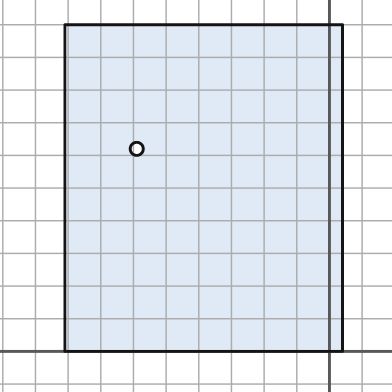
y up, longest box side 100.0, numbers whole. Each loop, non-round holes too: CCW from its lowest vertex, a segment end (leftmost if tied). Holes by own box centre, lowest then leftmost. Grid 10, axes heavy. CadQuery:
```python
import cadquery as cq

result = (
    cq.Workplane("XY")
    .moveTo(-81.0, 0.0)
    .lineTo(4.0, 0.0)
    .lineTo(4.0, 100.0)
    .lineTo(-81.0, 100.0)
    .close()
    .moveTo(-59.0, 62.0)
    .circle(2.0)
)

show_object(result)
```